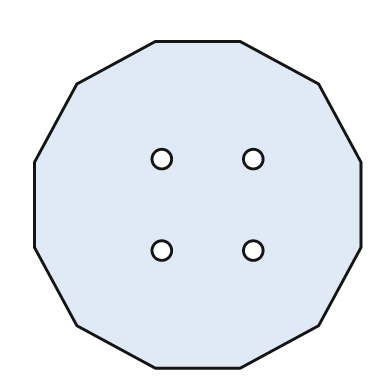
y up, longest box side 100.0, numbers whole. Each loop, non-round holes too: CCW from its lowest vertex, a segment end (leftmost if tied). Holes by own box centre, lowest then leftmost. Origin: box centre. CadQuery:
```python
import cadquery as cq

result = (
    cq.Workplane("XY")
    .moveTo(-13.0, -50.0)
    .lineTo(13.0, -50.0)
    .lineTo(37.0, -37.0)
    .lineTo(50.0, -13.0)
    .lineTo(50.0, 13.0)
    .lineTo(37.0, 37.0)
    .lineTo(13.0, 50.0)
    .lineTo(-13.0, 50.0)
    .lineTo(-37.0, 37.0)
    .lineTo(-50.0, 13.0)
    .lineTo(-50.0, -13.0)
    .lineTo(-37.0, -37.0)
    .close()
    .moveTo(-11.0, -14.0)
    .circle(3.0)
    .moveTo(17.0, -14.0)
    .circle(3.0)
    .moveTo(-11.0, 14.0)
    .circle(3.0)
    .moveTo(17.0, 14.0)
    .circle(3.0)
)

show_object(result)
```